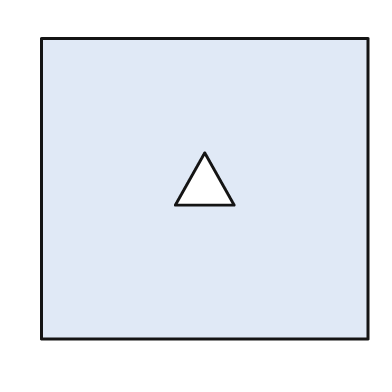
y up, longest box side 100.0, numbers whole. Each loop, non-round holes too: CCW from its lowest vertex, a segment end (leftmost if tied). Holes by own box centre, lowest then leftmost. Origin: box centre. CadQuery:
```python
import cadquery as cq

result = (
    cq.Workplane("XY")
    .moveTo(-50.0, -46.0)
    .lineTo(50.0, -46.0)
    .lineTo(50.0, 46.0)
    .lineTo(-50.0, 46.0)
    .close()
    .moveTo(-9.0, -5.0)
    .lineTo(9.0, -5.0)
    .lineTo(0.0, 11.0)
    .close()
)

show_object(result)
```